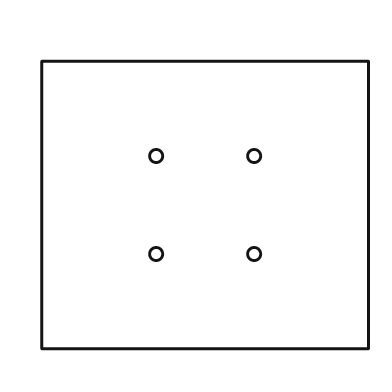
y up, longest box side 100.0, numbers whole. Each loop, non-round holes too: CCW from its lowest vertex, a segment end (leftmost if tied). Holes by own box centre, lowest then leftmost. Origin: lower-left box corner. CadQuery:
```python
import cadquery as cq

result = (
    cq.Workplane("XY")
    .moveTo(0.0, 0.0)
    .lineTo(100.0, 0.0)
    .lineTo(100.0, 88.0)
    .lineTo(0.0, 88.0)
    .close()
    .moveTo(35.0, 29.0)
    .circle(2.0)
    .moveTo(65.0, 29.0)
    .circle(2.0)
    .moveTo(35.0, 59.0)
    .circle(2.0)
    .moveTo(65.0, 59.0)
    .circle(2.0)
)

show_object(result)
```